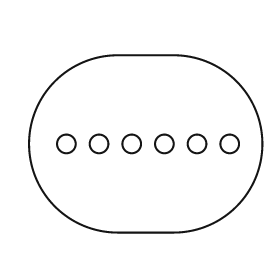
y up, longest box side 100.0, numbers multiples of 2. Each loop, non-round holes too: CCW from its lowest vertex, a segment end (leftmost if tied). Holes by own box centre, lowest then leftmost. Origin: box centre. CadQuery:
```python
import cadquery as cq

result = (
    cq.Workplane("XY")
    .moveTo(-12.0, -38.0)
    .lineTo(12.0, -38.0)
    .threePointArc((50.0, 0.0), (12.0, 38.0))
    .lineTo(-12.0, 38.0)
    .threePointArc((-50.0, 0.0), (-12.0, -38.0))
    .close()
    .moveTo(-34.0, 0.0)
    .circle(4.0)
    .moveTo(-20.0, 0.0)
    .circle(4.0)
    .moveTo(-6.0, 0.0)
    .circle(4.0)
    .moveTo(8.0, 0.0)
    .circle(4.0)
    .moveTo(22.0, 0.0)
    .circle(4.0)
    .moveTo(36.0, 0.0)
    .circle(4.0)
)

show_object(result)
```